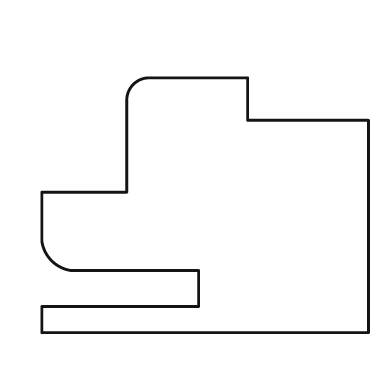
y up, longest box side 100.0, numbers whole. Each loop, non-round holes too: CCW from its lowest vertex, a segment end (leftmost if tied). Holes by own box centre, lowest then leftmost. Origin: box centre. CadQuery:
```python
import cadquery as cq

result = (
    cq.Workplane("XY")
    .moveTo(-50.0, -39.0)
    .lineTo(50.0, -39.0)
    .lineTo(50.0, 26.0)
    .lineTo(13.0, 26.0)
    .lineTo(13.0, 39.0)
    .lineTo(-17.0, 39.0)
    .threePointArc((-22.0, 37.0), (-24.0, 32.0))
    .lineTo(-24.0, 4.0)
    .lineTo(-50.0, 4.0)
    .lineTo(-50.0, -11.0)
    .threePointArc((-47.0, -17.0), (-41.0, -20.0))
    .lineTo(-2.0, -20.0)
    .lineTo(-2.0, -31.0)
    .lineTo(-50.0, -31.0)
    .close()
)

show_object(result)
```